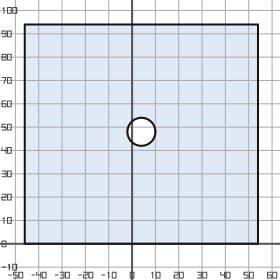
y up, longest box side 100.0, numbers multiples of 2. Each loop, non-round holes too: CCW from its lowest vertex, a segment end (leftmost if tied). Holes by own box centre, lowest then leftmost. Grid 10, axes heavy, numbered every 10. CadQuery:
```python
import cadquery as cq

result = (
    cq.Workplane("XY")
    .moveTo(-46.0, 0.0)
    .lineTo(54.0, 0.0)
    .lineTo(54.0, 94.0)
    .lineTo(-46.0, 94.0)
    .close()
    .moveTo(4.0, 48.0)
    .circle(6.0)
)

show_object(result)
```